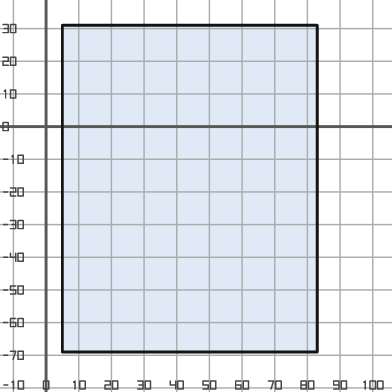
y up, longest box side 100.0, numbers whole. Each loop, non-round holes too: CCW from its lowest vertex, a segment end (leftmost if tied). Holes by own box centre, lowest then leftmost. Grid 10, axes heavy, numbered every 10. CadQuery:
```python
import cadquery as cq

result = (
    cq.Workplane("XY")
    .moveTo(5.0, -69.0)
    .lineTo(83.0, -69.0)
    .lineTo(83.0, 31.0)
    .lineTo(5.0, 31.0)
    .close()
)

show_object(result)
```